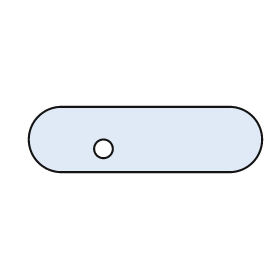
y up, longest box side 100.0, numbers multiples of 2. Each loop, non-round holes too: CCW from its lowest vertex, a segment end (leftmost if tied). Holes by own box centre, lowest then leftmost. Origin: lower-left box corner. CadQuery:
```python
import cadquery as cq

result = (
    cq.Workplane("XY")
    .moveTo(14.0, 0.0)
    .lineTo(86.0, 0.0)
    .threePointArc((100.0, 14.0), (86.0, 28.0))
    .lineTo(14.0, 28.0)
    .threePointArc((0.0, 14.0), (14.0, 0.0))
    .close()
    .moveTo(32.0, 10.0)
    .circle(4.0)
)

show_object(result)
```